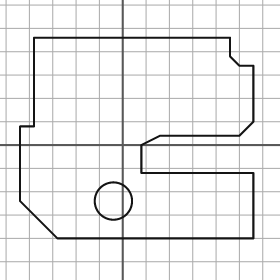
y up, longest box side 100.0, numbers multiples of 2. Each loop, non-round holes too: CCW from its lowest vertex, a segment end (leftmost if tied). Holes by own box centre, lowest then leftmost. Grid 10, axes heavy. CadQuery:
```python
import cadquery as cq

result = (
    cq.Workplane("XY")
    .moveTo(-28.0, -40.0)
    .lineTo(56.0, -40.0)
    .lineTo(56.0, -12.0)
    .lineTo(8.0, -12.0)
    .lineTo(8.0, 0.0)
    .lineTo(16.0, 4.0)
    .lineTo(50.0, 4.0)
    .lineTo(56.0, 10.0)
    .lineTo(56.0, 34.0)
    .lineTo(50.0, 34.0)
    .lineTo(46.0, 38.0)
    .lineTo(46.0, 46.0)
    .lineTo(-38.0, 46.0)
    .lineTo(-38.0, 8.0)
    .lineTo(-44.0, 8.0)
    .lineTo(-44.0, -24.0)
    .close()
    .moveTo(-4.0, -24.0)
    .circle(8.0)
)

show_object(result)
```